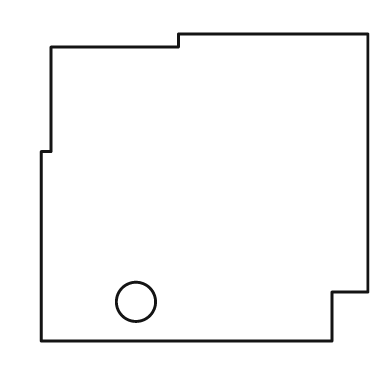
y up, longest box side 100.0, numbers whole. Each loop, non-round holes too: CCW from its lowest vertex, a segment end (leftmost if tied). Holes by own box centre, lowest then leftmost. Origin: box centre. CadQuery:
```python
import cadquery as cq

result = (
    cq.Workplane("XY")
    .moveTo(-50.0, -47.0)
    .lineTo(39.0, -47.0)
    .lineTo(39.0, -32.0)
    .lineTo(50.0, -32.0)
    .lineTo(50.0, 47.0)
    .lineTo(-8.0, 47.0)
    .lineTo(-8.0, 43.0)
    .lineTo(-47.0, 43.0)
    .lineTo(-47.0, 11.0)
    .lineTo(-50.0, 11.0)
    .close()
    .moveTo(-21.0, -35.0)
    .circle(6.0)
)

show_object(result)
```